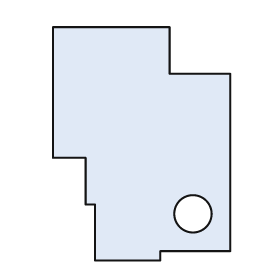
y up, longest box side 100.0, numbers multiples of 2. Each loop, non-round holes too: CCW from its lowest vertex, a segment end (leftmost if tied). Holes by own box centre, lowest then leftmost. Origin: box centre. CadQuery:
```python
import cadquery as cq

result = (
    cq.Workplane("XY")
    .moveTo(-20.0, -50.0)
    .lineTo(8.0, -50.0)
    .lineTo(8.0, -46.0)
    .lineTo(38.0, -46.0)
    .lineTo(38.0, 30.0)
    .lineTo(12.0, 30.0)
    .lineTo(12.0, 50.0)
    .lineTo(-38.0, 50.0)
    .lineTo(-38.0, -6.0)
    .lineTo(-24.0, -6.0)
    .lineTo(-24.0, -26.0)
    .lineTo(-20.0, -26.0)
    .close()
    .moveTo(22.0, -30.0)
    .circle(8.0)
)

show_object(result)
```